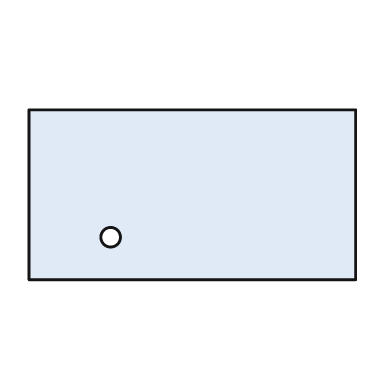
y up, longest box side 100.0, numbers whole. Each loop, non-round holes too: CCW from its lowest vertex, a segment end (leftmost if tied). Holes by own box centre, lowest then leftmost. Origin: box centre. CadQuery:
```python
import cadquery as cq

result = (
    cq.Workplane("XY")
    .moveTo(-50.0, -26.0)
    .lineTo(50.0, -26.0)
    .lineTo(50.0, 26.0)
    .lineTo(-50.0, 26.0)
    .close()
    .moveTo(-25.0, -13.0)
    .circle(3.0)
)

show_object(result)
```